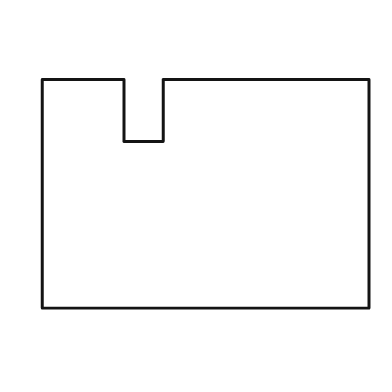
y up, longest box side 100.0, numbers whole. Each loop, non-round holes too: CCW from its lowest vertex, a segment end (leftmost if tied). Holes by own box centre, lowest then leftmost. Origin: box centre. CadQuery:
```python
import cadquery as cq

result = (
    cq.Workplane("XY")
    .moveTo(-50.0, -35.0)
    .lineTo(50.0, -35.0)
    .lineTo(50.0, 35.0)
    .lineTo(-13.0, 35.0)
    .lineTo(-13.0, 16.0)
    .lineTo(-25.0, 16.0)
    .lineTo(-25.0, 35.0)
    .lineTo(-50.0, 35.0)
    .close()
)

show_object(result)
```